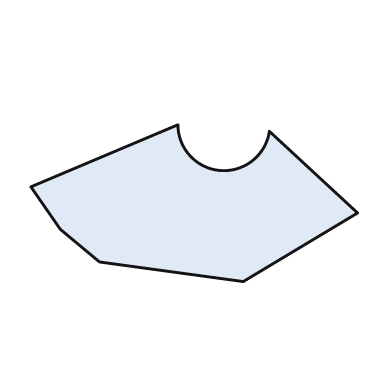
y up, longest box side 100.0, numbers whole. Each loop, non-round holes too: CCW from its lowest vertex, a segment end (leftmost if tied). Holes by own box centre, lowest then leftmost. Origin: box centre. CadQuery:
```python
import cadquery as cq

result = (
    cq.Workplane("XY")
    .moveTo(15.0, -24.0)
    .lineTo(50.0, -3.0)
    .lineTo(23.0, 22.0)
    .threePointArc((8.0, 10.0), (-5.0, 24.0))
    .lineTo(-50.0, 5.0)
    .lineTo(-41.0, -8.0)
    .lineTo(-29.0, -18.0)
    .close()
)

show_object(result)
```